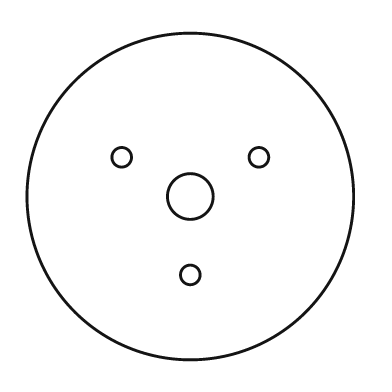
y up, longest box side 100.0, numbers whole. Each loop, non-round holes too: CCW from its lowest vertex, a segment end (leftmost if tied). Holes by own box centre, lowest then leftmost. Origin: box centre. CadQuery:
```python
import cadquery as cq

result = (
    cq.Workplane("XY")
    .moveTo(0.0, 0.0)
    .circle(50.0)
    .moveTo(0.0, -24.0)
    .circle(3.0)
    .moveTo(0.0, 0.0)
    .circle(7.0)
    .moveTo(-21.0, 12.0)
    .circle(3.0)
    .moveTo(21.0, 12.0)
    .circle(3.0)
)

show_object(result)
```